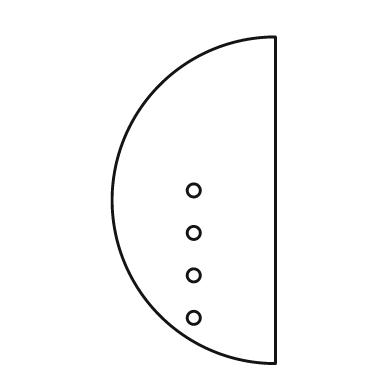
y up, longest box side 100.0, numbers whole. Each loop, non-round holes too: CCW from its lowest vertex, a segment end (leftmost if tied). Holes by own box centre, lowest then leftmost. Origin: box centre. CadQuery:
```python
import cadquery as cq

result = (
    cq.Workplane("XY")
    .moveTo(25.0, -50.0)
    .lineTo(25.0, 50.0)
    .threePointArc((-25.0, 0.0), (25.0, -50.0))
    .close()
    .moveTo(0.0, -36.0)
    .circle(2.0)
    .moveTo(0.0, -23.0)
    .circle(2.0)
    .moveTo(0.0, -10.0)
    .circle(2.0)
    .moveTo(0.0, 3.0)
    .circle(2.0)
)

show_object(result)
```